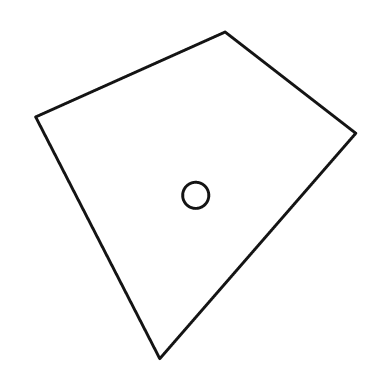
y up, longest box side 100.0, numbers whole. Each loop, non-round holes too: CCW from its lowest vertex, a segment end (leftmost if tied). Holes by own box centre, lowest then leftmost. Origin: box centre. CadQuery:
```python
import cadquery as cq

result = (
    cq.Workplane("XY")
    .moveTo(-11.0, -50.0)
    .lineTo(49.0, 19.0)
    .lineTo(9.0, 50.0)
    .lineTo(-49.0, 24.0)
    .close()
    .moveTo(0.0, 0.0)
    .circle(4.0)
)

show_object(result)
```